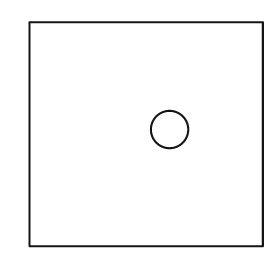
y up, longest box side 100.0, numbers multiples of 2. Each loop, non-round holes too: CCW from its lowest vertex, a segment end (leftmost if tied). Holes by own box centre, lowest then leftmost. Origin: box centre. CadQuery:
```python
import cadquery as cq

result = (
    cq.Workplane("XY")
    .moveTo(-50.0, -48.0)
    .lineTo(50.0, -48.0)
    .lineTo(50.0, 48.0)
    .lineTo(-50.0, 48.0)
    .close()
    .moveTo(10.0, 2.0)
    .circle(8.0)
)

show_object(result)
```